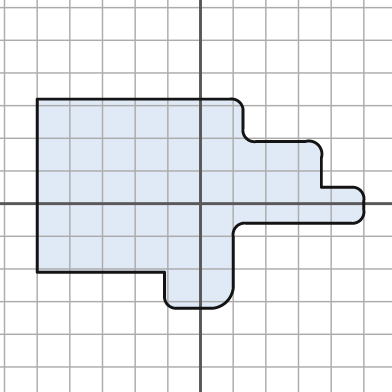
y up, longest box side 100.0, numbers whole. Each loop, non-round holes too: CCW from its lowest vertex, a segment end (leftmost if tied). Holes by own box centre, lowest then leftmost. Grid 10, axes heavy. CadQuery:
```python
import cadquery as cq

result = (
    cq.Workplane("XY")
    .moveTo(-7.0, -32.0)
    .lineTo(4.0, -32.0)
    .threePointArc((8.0, -30.0), (10.0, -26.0))
    .lineTo(10.0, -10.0)
    .threePointArc((11.0, -7.0), (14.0, -6.0))
    .lineTo(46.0, -6.0)
    .threePointArc((49.0, -5.0), (50.0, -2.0))
    .lineTo(50.0, 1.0)
    .threePointArc((49.0, 4.0), (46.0, 5.0))
    .lineTo(37.0, 5.0)
    .lineTo(37.0, 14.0)
    .threePointArc((36.0, 18.0), (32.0, 19.0))
    .lineTo(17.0, 19.0)
    .threePointArc((14.0, 20.0), (13.0, 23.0))
    .lineTo(13.0, 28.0)
    .threePointArc((12.0, 31.0), (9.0, 32.0))
    .lineTo(-50.0, 32.0)
    .lineTo(-50.0, -21.0)
    .lineTo(-11.0, -21.0)
    .lineTo(-11.0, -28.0)
    .threePointArc((-10.0, -31.0), (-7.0, -32.0))
    .close()
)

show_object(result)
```